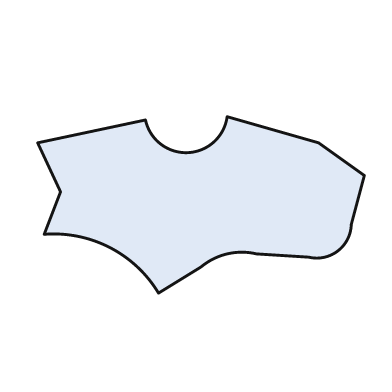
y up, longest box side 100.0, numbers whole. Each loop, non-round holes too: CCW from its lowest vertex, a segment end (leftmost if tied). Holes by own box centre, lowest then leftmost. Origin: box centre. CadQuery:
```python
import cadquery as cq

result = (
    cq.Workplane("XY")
    .moveTo(-13.0, -27.0)
    .lineTo(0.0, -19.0)
    .threePointArc((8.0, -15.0), (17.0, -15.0))
    .lineTo(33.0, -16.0)
    .threePointArc((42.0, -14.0), (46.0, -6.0))
    .lineTo(50.0, 9.0)
    .lineTo(36.0, 19.0)
    .lineTo(8.0, 27.0)
    .threePointArc((-4.0, 16.0), (-17.0, 26.0))
    .lineTo(-50.0, 19.0)
    .lineTo(-43.0, 4.0)
    .lineTo(-48.0, -9.0)
    .threePointArc((-28.0, -13.0), (-13.0, -27.0))
    .close()
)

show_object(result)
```